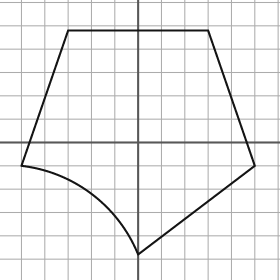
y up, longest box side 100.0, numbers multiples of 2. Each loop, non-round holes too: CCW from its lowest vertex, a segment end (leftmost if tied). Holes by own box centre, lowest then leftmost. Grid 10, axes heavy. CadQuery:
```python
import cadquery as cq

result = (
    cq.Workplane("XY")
    .moveTo(0.0, -48.0)
    .lineTo(50.0, -10.0)
    .lineTo(30.0, 48.0)
    .lineTo(-30.0, 48.0)
    .lineTo(-50.0, -10.0)
    .threePointArc((-20.0, -22.0), (0.0, -48.0))
    .close()
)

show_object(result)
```